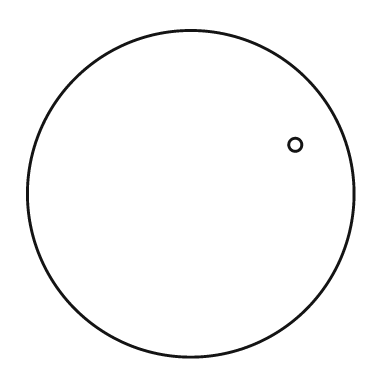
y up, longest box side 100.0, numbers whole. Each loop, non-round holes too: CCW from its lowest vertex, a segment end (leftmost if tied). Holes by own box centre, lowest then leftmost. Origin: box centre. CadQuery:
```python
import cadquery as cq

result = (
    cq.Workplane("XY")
    .moveTo(0.0, 0.0)
    .circle(50.0)
    .moveTo(32.0, 15.0)
    .circle(2.0)
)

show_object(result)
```